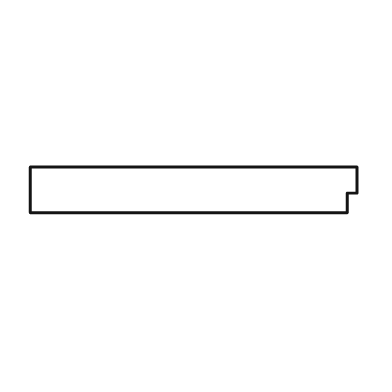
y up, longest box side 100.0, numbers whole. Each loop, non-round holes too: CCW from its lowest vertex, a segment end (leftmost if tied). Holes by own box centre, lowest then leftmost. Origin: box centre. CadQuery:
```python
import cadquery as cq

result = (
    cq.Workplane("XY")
    .moveTo(-50.0, -7.0)
    .lineTo(47.0, -7.0)
    .lineTo(47.0, -1.0)
    .lineTo(50.0, -1.0)
    .lineTo(50.0, 7.0)
    .lineTo(-50.0, 7.0)
    .close()
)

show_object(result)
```